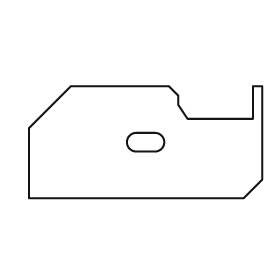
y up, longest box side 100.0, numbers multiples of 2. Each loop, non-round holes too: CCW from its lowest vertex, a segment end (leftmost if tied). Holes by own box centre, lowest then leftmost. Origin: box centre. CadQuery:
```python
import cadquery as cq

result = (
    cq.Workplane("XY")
    .moveTo(-50.0, -24.0)
    .lineTo(42.0, -24.0)
    .lineTo(50.0, -16.0)
    .lineTo(50.0, 24.0)
    .lineTo(46.0, 24.0)
    .lineTo(46.0, 10.0)
    .lineTo(18.0, 10.0)
    .lineTo(14.0, 16.0)
    .lineTo(14.0, 20.0)
    .lineTo(10.0, 24.0)
    .lineTo(-32.0, 24.0)
    .lineTo(-50.0, 6.0)
    .close()
    .moveTo(-4.0, -4.0)
    .lineTo(4.0, -4.0)
    .threePointArc((8.0, 0.0), (4.0, 4.0))
    .lineTo(-4.0, 4.0)
    .threePointArc((-8.0, 0.0), (-4.0, -4.0))
    .close()
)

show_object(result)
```